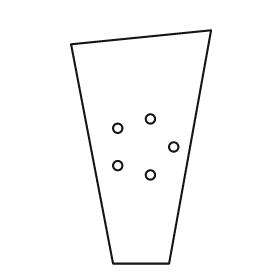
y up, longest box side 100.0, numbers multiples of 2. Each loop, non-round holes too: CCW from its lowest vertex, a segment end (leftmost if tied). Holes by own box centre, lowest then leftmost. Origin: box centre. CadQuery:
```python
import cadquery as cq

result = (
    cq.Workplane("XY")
    .moveTo(-12.0, -50.0)
    .lineTo(12.0, -50.0)
    .lineTo(30.0, 50.0)
    .lineTo(-30.0, 44.0)
    .close()
    .moveTo(4.0, -12.0)
    .circle(2.0)
    .moveTo(-10.0, -8.0)
    .circle(2.0)
    .moveTo(14.0, 0.0)
    .circle(2.0)
    .moveTo(-10.0, 8.0)
    .circle(2.0)
    .moveTo(4.0, 12.0)
    .circle(2.0)
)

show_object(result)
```